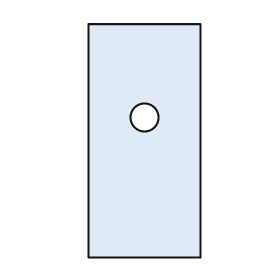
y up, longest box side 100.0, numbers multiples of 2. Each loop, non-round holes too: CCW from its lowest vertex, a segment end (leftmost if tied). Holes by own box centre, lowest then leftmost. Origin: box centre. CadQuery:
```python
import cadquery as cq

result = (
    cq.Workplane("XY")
    .moveTo(-24.0, -50.0)
    .lineTo(24.0, -50.0)
    .lineTo(24.0, 50.0)
    .lineTo(-24.0, 50.0)
    .close()
    .moveTo(0.0, 10.0)
    .circle(6.0)
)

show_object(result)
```